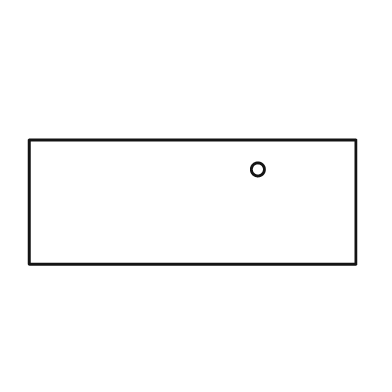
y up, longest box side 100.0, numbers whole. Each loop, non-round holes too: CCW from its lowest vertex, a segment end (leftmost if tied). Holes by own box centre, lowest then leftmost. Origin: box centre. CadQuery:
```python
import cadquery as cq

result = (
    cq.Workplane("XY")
    .moveTo(-50.0, -19.0)
    .lineTo(50.0, -19.0)
    .lineTo(50.0, 19.0)
    .lineTo(-50.0, 19.0)
    .close()
    .moveTo(20.0, 10.0)
    .circle(2.0)
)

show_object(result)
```